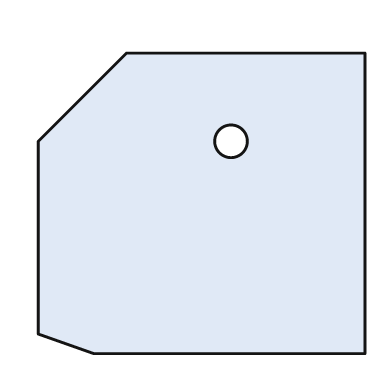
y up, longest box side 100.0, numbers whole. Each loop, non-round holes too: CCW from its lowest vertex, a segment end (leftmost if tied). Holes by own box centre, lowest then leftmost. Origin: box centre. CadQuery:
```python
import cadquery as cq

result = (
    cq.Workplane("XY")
    .moveTo(-33.0, -46.0)
    .lineTo(50.0, -46.0)
    .lineTo(50.0, 46.0)
    .lineTo(-23.0, 46.0)
    .lineTo(-50.0, 19.0)
    .lineTo(-50.0, -40.0)
    .close()
    .moveTo(9.0, 19.0)
    .circle(5.0)
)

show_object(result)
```